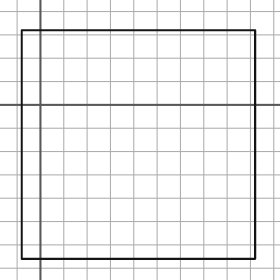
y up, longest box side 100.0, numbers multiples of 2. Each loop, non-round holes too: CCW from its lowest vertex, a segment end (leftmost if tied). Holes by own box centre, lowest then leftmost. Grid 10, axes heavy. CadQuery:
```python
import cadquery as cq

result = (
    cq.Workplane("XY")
    .moveTo(-8.0, -66.0)
    .lineTo(92.0, -66.0)
    .lineTo(92.0, 32.0)
    .lineTo(-8.0, 32.0)
    .close()
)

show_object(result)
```